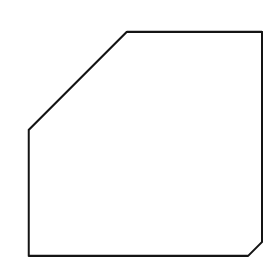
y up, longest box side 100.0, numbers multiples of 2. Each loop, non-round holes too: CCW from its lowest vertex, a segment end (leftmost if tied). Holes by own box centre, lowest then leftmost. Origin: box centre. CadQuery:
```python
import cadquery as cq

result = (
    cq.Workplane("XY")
    .moveTo(-50.0, -48.0)
    .lineTo(44.0, -48.0)
    .lineTo(50.0, -42.0)
    .lineTo(50.0, 48.0)
    .lineTo(-8.0, 48.0)
    .lineTo(-50.0, 6.0)
    .close()
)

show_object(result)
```